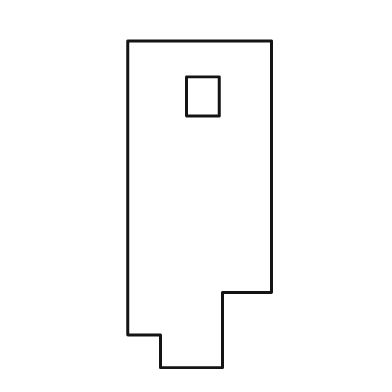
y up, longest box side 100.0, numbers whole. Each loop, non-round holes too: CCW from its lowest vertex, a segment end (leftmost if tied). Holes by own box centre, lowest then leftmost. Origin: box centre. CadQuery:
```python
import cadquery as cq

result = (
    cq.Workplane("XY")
    .moveTo(-12.0, -50.0)
    .lineTo(7.0, -50.0)
    .lineTo(7.0, -27.0)
    .lineTo(22.0, -27.0)
    .lineTo(22.0, 50.0)
    .lineTo(-22.0, 50.0)
    .lineTo(-22.0, -40.0)
    .lineTo(-12.0, -40.0)
    .close()
    .moveTo(-4.0, 27.0)
    .lineTo(6.0, 27.0)
    .lineTo(6.0, 39.0)
    .lineTo(-4.0, 39.0)
    .close()
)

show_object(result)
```